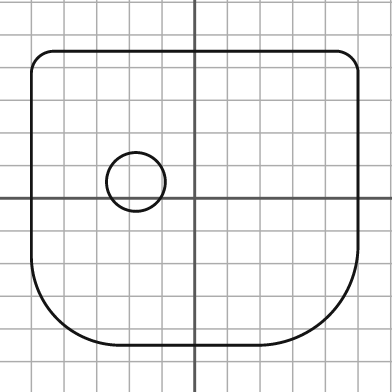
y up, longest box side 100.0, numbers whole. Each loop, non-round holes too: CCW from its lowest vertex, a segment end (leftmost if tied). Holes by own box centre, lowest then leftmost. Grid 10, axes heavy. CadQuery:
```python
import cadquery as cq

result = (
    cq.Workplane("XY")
    .moveTo(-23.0, -45.0)
    .lineTo(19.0, -45.0)
    .threePointArc((41.0, -36.0), (50.0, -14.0))
    .lineTo(50.0, 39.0)
    .threePointArc((48.0, 43.0), (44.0, 45.0))
    .lineTo(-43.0, 45.0)
    .threePointArc((-48.0, 43.0), (-50.0, 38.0))
    .lineTo(-50.0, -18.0)
    .threePointArc((-42.0, -37.0), (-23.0, -45.0))
    .close()
    .moveTo(-18.0, 5.0)
    .circle(9.0)
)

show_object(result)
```